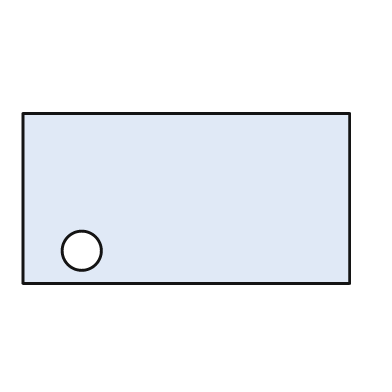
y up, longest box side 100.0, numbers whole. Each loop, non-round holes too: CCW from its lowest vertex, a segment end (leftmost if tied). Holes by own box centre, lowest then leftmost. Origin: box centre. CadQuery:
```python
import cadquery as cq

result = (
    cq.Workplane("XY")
    .moveTo(-50.0, -26.0)
    .lineTo(50.0, -26.0)
    .lineTo(50.0, 26.0)
    .lineTo(-50.0, 26.0)
    .close()
    .moveTo(-32.0, -16.0)
    .circle(6.0)
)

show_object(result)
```